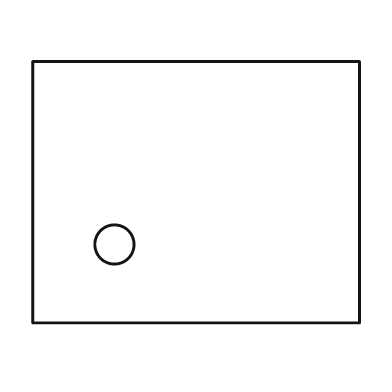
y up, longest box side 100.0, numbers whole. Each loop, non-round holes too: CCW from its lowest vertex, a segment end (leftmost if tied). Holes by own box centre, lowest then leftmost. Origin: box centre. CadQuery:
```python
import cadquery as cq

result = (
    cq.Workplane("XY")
    .moveTo(-50.0, -40.0)
    .lineTo(50.0, -40.0)
    .lineTo(50.0, 40.0)
    .lineTo(-50.0, 40.0)
    .close()
    .moveTo(-25.0, -16.0)
    .circle(6.0)
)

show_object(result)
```